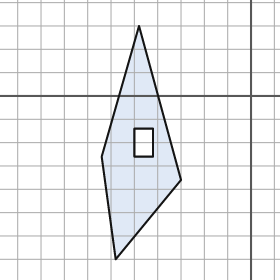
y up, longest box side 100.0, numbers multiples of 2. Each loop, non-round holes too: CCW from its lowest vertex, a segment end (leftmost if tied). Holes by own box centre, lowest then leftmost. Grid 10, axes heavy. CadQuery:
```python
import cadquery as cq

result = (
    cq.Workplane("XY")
    .moveTo(-58.0, -70.0)
    .lineTo(-30.0, -36.0)
    .lineTo(-48.0, 30.0)
    .lineTo(-64.0, -26.0)
    .close()
    .moveTo(-50.0, -26.0)
    .lineTo(-42.0, -26.0)
    .lineTo(-42.0, -14.0)
    .lineTo(-50.0, -14.0)
    .close()
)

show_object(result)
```